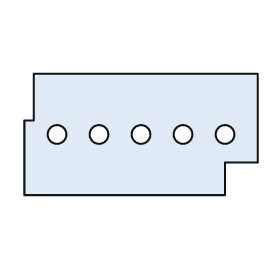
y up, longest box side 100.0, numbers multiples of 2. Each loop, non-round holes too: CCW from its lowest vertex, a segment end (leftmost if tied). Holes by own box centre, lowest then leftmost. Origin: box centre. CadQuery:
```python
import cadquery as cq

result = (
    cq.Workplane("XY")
    .moveTo(-50.0, -26.0)
    .lineTo(36.0, -26.0)
    .lineTo(36.0, -12.0)
    .lineTo(50.0, -12.0)
    .lineTo(50.0, 26.0)
    .lineTo(-46.0, 26.0)
    .lineTo(-46.0, 6.0)
    .lineTo(-50.0, 6.0)
    .close()
    .moveTo(-36.0, 0.0)
    .circle(4.0)
    .moveTo(-18.0, 0.0)
    .circle(4.0)
    .moveTo(0.0, 0.0)
    .circle(4.0)
    .moveTo(18.0, 0.0)
    .circle(4.0)
    .moveTo(36.0, 0.0)
    .circle(4.0)
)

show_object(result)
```